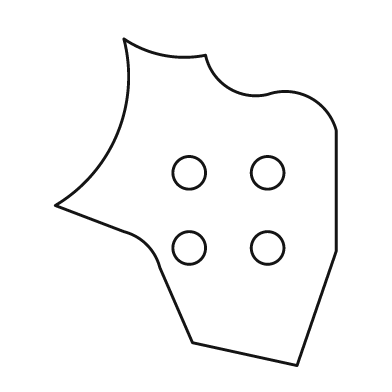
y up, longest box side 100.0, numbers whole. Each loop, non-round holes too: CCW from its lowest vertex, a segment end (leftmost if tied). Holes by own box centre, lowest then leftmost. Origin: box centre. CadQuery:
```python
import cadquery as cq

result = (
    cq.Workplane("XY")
    .moveTo(31.0, -50.0)
    .lineTo(43.0, -15.0)
    .lineTo(43.0, 22.0)
    .threePointArc((35.0, 32.0), (22.0, 33.0))
    .threePointArc((10.0, 35.0), (3.0, 45.0))
    .threePointArc((-10.0, 45.0), (-22.0, 50.0))
    .threePointArc((-24.0, 21.0), (-43.0, -1.0))
    .lineTo(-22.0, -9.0)
    .threePointArc((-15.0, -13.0), (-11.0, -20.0))
    .lineTo(-1.0, -43.0)
    .close()
    .moveTo(-2.0, -14.0)
    .circle(5.0)
    .moveTo(22.0, -14.0)
    .circle(5.0)
    .moveTo(-2.0, 9.0)
    .circle(5.0)
    .moveTo(22.0, 9.0)
    .circle(5.0)
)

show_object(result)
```